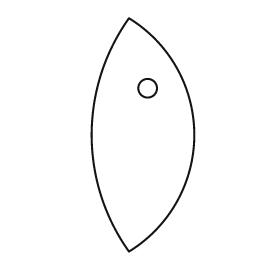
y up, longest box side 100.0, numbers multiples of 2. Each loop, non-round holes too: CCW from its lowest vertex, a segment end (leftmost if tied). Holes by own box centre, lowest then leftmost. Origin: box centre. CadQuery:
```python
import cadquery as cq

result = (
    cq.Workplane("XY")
    .moveTo(-6.0, -50.0)
    .threePointArc((22.0, 0.0), (-6.0, 50.0))
    .threePointArc((-22.0, 0.0), (-6.0, -50.0))
    .close()
    .moveTo(2.0, 20.0)
    .circle(4.0)
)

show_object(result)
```